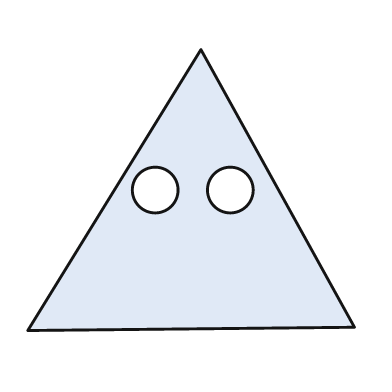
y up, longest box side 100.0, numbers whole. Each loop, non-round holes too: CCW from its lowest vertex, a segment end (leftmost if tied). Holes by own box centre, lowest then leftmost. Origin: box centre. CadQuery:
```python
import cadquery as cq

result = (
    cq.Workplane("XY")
    .moveTo(-50.0, -43.0)
    .lineTo(50.0, -42.0)
    .lineTo(3.0, 43.0)
    .close()
    .moveTo(-11.0, 0.0)
    .circle(7.0)
    .moveTo(12.0, 0.0)
    .circle(7.0)
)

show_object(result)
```